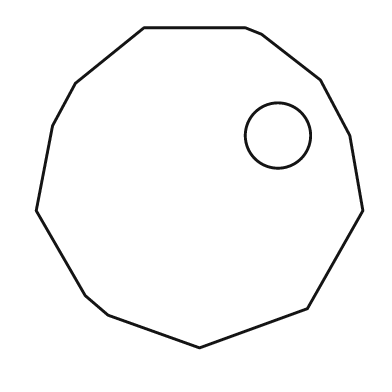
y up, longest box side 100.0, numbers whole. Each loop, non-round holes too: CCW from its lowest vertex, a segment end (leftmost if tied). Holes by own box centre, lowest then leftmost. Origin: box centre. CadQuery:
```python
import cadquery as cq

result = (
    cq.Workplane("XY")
    .moveTo(0.0, -49.0)
    .lineTo(33.0, -37.0)
    .lineTo(50.0, -7.0)
    .lineTo(46.0, 16.0)
    .lineTo(37.0, 33.0)
    .lineTo(19.0, 47.0)
    .lineTo(14.0, 49.0)
    .lineTo(-17.0, 49.0)
    .lineTo(-38.0, 32.0)
    .lineTo(-45.0, 19.0)
    .lineTo(-50.0, -7.0)
    .lineTo(-35.0, -33.0)
    .lineTo(-28.0, -39.0)
    .close()
    .moveTo(24.0, 16.0)
    .circle(10.0)
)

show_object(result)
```